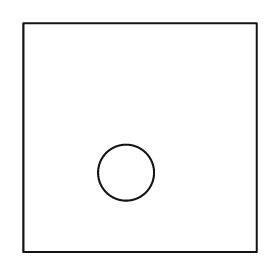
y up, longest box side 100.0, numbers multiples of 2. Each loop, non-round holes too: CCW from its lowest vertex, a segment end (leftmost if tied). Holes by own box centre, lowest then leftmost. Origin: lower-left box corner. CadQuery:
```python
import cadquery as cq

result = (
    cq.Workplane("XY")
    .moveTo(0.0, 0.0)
    .lineTo(100.0, 0.0)
    .lineTo(100.0, 98.0)
    .lineTo(0.0, 98.0)
    .close()
    .moveTo(44.0, 34.0)
    .circle(12.0)
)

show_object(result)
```